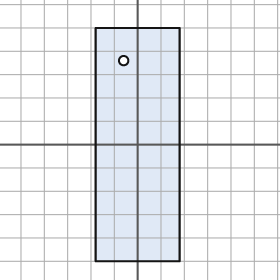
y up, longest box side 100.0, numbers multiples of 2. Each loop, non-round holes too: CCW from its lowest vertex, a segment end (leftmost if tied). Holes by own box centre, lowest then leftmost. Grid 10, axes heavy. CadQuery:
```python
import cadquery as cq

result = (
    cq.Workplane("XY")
    .moveTo(-18.0, -50.0)
    .lineTo(18.0, -50.0)
    .lineTo(18.0, 50.0)
    .lineTo(-18.0, 50.0)
    .close()
    .moveTo(-6.0, 36.0)
    .circle(2.0)
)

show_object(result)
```